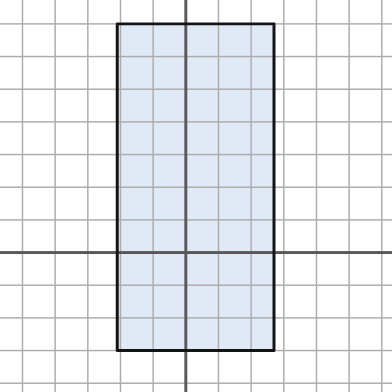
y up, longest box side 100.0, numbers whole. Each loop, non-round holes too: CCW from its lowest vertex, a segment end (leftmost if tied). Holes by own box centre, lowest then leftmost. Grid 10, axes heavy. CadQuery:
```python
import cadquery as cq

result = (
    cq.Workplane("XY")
    .moveTo(-21.0, -30.0)
    .lineTo(27.0, -30.0)
    .lineTo(27.0, 70.0)
    .lineTo(-21.0, 70.0)
    .close()
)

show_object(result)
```